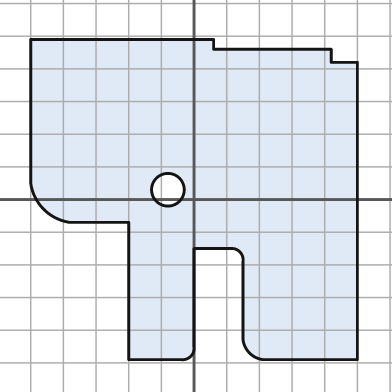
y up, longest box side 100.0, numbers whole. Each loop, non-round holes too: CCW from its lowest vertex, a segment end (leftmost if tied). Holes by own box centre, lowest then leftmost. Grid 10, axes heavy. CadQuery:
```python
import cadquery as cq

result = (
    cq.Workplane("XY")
    .moveTo(-20.0, -49.0)
    .lineTo(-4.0, -49.0)
    .threePointArc((-1.0, -48.0), (0.0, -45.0))
    .lineTo(0.0, -15.0)
    .lineTo(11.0, -15.0)
    .threePointArc((14.0, -16.0), (15.0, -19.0))
    .lineTo(15.0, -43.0)
    .threePointArc((17.0, -47.0), (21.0, -49.0))
    .lineTo(50.0, -49.0)
    .lineTo(50.0, 42.0)
    .lineTo(42.0, 42.0)
    .lineTo(42.0, 46.0)
    .lineTo(6.0, 46.0)
    .lineTo(6.0, 49.0)
    .lineTo(-50.0, 49.0)
    .lineTo(-50.0, 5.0)
    .threePointArc((-46.0, -3.0), (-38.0, -7.0))
    .lineTo(-20.0, -7.0)
    .close()
    .moveTo(-8.0, 3.0)
    .circle(5.0)
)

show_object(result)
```